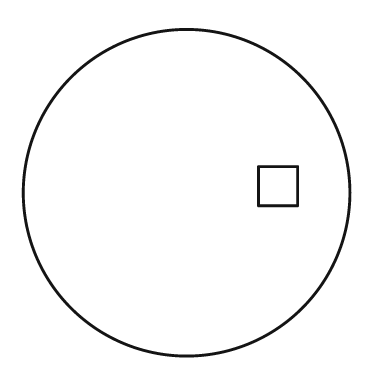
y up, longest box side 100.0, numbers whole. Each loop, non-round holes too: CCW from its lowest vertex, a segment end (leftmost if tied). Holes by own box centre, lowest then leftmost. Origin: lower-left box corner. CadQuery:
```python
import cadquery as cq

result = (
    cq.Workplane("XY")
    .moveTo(50.0, 50.0)
    .circle(50.0)
    .moveTo(72.0, 46.0)
    .lineTo(84.0, 46.0)
    .lineTo(84.0, 58.0)
    .lineTo(72.0, 58.0)
    .close()
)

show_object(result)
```